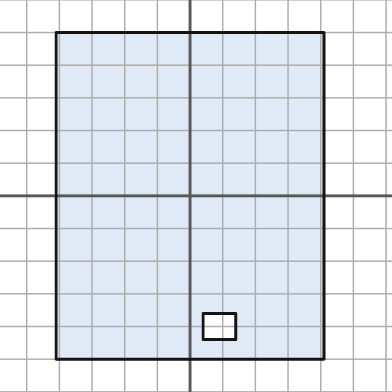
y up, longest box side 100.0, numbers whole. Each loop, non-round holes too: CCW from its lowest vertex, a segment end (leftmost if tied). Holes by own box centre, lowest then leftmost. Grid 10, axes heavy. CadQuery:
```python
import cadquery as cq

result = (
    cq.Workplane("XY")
    .moveTo(-41.0, -50.0)
    .lineTo(41.0, -50.0)
    .lineTo(41.0, 50.0)
    .lineTo(-41.0, 50.0)
    .close()
    .moveTo(4.0, -44.0)
    .lineTo(14.0, -44.0)
    .lineTo(14.0, -36.0)
    .lineTo(4.0, -36.0)
    .close()
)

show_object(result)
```